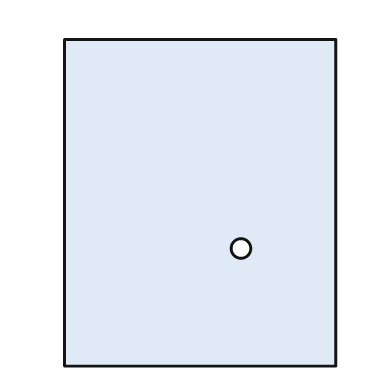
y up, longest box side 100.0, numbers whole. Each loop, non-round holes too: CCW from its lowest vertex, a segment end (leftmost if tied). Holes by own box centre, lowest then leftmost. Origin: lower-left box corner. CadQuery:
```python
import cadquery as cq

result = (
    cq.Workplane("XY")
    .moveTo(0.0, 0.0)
    .lineTo(83.0, 0.0)
    .lineTo(83.0, 100.0)
    .lineTo(0.0, 100.0)
    .close()
    .moveTo(54.0, 36.0)
    .circle(3.0)
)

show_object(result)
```